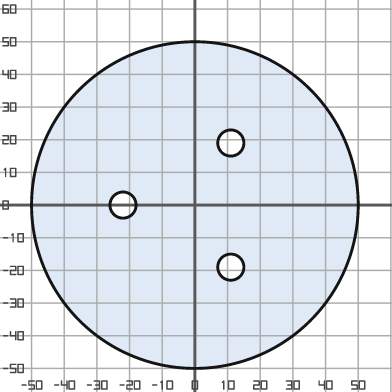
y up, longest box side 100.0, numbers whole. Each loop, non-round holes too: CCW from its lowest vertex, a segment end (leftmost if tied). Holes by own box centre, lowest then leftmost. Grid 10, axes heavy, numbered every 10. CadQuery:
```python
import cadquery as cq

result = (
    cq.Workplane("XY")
    .moveTo(0.0, 0.0)
    .circle(50.0)
    .moveTo(11.0, -19.0)
    .circle(4.0)
    .moveTo(-22.0, 0.0)
    .circle(4.0)
    .moveTo(11.0, 19.0)
    .circle(4.0)
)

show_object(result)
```